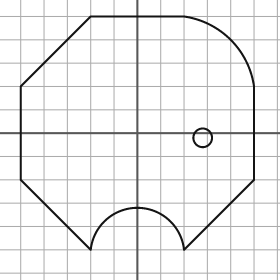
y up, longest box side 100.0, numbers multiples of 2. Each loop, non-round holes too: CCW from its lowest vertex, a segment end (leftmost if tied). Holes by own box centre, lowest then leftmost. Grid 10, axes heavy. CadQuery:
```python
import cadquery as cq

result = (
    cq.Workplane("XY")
    .moveTo(-20.0, -50.0)
    .threePointArc((0.0, -32.0), (20.0, -50.0))
    .lineTo(50.0, -20.0)
    .lineTo(50.0, 20.0)
    .threePointArc((40.0, 40.0), (20.0, 50.0))
    .lineTo(-20.0, 50.0)
    .lineTo(-50.0, 20.0)
    .lineTo(-50.0, -20.0)
    .close()
    .moveTo(28.0, -2.0)
    .circle(4.0)
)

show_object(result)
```